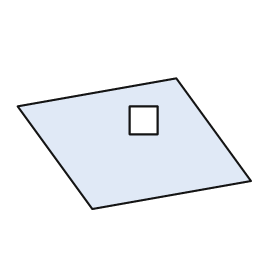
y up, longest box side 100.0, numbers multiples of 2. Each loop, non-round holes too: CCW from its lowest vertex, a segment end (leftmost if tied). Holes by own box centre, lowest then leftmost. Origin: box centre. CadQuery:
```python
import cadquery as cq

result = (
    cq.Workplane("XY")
    .moveTo(-18.0, -28.0)
    .lineTo(50.0, -16.0)
    .lineTo(18.0, 28.0)
    .lineTo(-50.0, 16.0)
    .close()
    .moveTo(-2.0, 4.0)
    .lineTo(10.0, 4.0)
    .lineTo(10.0, 16.0)
    .lineTo(-2.0, 16.0)
    .close()
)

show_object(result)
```